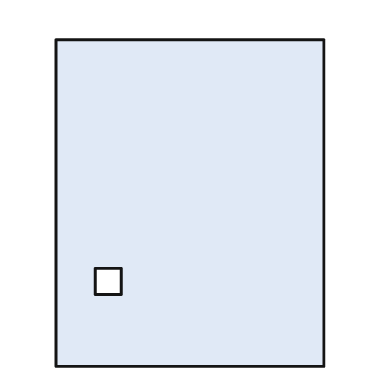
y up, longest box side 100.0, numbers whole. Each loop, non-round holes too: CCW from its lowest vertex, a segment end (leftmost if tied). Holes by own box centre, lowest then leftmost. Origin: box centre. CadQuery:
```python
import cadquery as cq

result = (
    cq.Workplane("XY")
    .moveTo(-41.0, -50.0)
    .lineTo(41.0, -50.0)
    .lineTo(41.0, 50.0)
    .lineTo(-41.0, 50.0)
    .close()
    .moveTo(-29.0, -28.0)
    .lineTo(-21.0, -28.0)
    .lineTo(-21.0, -20.0)
    .lineTo(-29.0, -20.0)
    .close()
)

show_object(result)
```